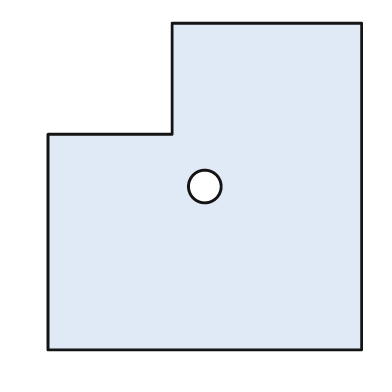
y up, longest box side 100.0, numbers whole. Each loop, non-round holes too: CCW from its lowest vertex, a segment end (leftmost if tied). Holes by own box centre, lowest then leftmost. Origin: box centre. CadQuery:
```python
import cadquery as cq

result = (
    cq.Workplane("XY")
    .moveTo(-48.0, -50.0)
    .lineTo(48.0, -50.0)
    .lineTo(48.0, 50.0)
    .lineTo(-10.0, 50.0)
    .lineTo(-10.0, 16.0)
    .lineTo(-48.0, 16.0)
    .close()
    .moveTo(0.0, 0.0)
    .circle(5.0)
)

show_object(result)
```